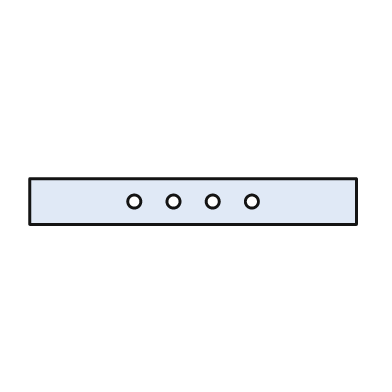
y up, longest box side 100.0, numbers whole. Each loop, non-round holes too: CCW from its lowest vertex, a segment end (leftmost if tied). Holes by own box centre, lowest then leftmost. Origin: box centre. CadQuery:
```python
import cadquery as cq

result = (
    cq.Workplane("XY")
    .moveTo(-50.0, -7.0)
    .lineTo(50.0, -7.0)
    .lineTo(50.0, 7.0)
    .lineTo(-50.0, 7.0)
    .close()
    .moveTo(-18.0, 0.0)
    .circle(2.0)
    .moveTo(-6.0, 0.0)
    .circle(2.0)
    .moveTo(6.0, 0.0)
    .circle(2.0)
    .moveTo(18.0, 0.0)
    .circle(2.0)
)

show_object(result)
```